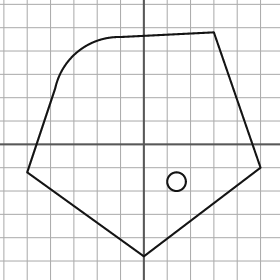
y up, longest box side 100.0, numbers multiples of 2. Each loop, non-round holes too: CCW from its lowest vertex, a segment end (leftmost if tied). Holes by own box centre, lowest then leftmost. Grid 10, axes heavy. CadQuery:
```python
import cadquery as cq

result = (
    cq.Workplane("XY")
    .moveTo(0.0, -48.0)
    .lineTo(50.0, -10.0)
    .lineTo(30.0, 48.0)
    .lineTo(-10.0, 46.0)
    .threePointArc((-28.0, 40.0), (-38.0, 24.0))
    .lineTo(-50.0, -12.0)
    .close()
    .moveTo(14.0, -16.0)
    .circle(4.0)
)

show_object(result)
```